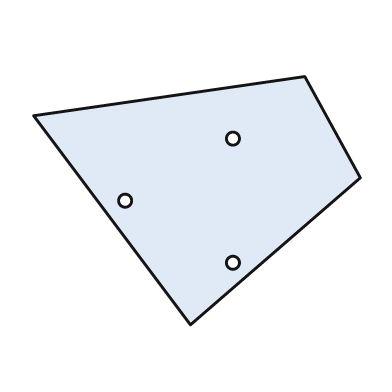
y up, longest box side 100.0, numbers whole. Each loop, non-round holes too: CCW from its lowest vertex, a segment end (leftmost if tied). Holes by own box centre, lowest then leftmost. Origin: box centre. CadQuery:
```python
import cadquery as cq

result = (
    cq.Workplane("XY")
    .moveTo(-2.0, -38.0)
    .lineTo(50.0, 7.0)
    .lineTo(33.0, 38.0)
    .lineTo(-50.0, 26.0)
    .close()
    .moveTo(11.0, -19.0)
    .circle(2.0)
    .moveTo(-22.0, 0.0)
    .circle(2.0)
    .moveTo(11.0, 19.0)
    .circle(2.0)
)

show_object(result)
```